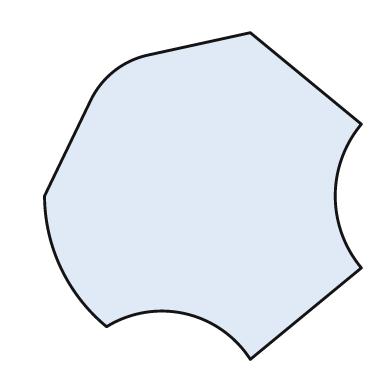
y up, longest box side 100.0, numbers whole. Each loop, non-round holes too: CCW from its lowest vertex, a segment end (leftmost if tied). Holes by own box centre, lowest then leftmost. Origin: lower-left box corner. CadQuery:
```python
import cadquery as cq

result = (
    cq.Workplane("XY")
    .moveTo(63.0, 0.0)
    .lineTo(97.0, 28.0)
    .threePointArc((89.0, 50.0), (97.0, 72.0))
    .lineTo(63.0, 100.0)
    .lineTo(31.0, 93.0)
    .threePointArc((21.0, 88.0), (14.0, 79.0))
    .lineTo(0.0, 50.0)
    .threePointArc((5.0, 28.0), (19.0, 10.0))
    .threePointArc((43.0, 14.0), (63.0, 0.0))
    .close()
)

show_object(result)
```